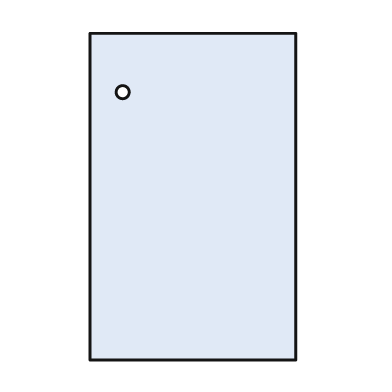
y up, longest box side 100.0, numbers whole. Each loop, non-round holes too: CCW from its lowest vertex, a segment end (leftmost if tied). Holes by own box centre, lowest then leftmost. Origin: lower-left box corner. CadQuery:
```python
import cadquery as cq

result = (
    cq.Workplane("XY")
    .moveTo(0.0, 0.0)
    .lineTo(63.0, 0.0)
    .lineTo(63.0, 100.0)
    .lineTo(0.0, 100.0)
    .close()
    .moveTo(10.0, 82.0)
    .circle(2.0)
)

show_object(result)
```